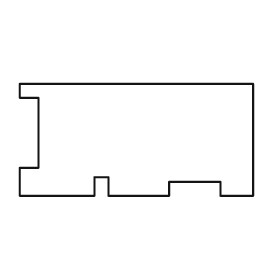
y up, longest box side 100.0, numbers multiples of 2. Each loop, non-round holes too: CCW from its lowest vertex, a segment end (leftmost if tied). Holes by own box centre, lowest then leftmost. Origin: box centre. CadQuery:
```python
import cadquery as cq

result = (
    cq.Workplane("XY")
    .moveTo(-50.0, -24.0)
    .lineTo(-18.0, -24.0)
    .lineTo(-18.0, -16.0)
    .lineTo(-12.0, -16.0)
    .lineTo(-12.0, -24.0)
    .lineTo(14.0, -24.0)
    .lineTo(14.0, -18.0)
    .lineTo(36.0, -18.0)
    .lineTo(36.0, -24.0)
    .lineTo(50.0, -24.0)
    .lineTo(50.0, 24.0)
    .lineTo(-50.0, 24.0)
    .lineTo(-50.0, 18.0)
    .lineTo(-42.0, 18.0)
    .lineTo(-42.0, -12.0)
    .lineTo(-50.0, -12.0)
    .close()
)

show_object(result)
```